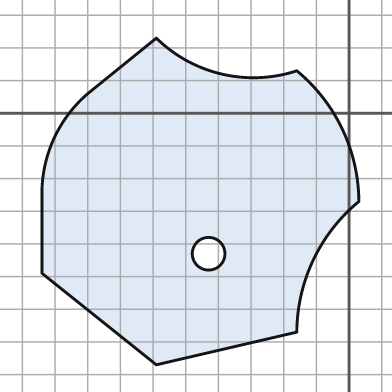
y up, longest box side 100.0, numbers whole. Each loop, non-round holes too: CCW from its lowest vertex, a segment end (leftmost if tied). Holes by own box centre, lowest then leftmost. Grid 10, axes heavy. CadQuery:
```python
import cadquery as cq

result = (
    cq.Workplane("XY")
    .moveTo(-59.0, -77.0)
    .lineTo(-16.0, -67.0)
    .threePointArc((-11.0, -45.0), (3.0, -27.0))
    .threePointArc((-2.0, -5.0), (-16.0, 13.0))
    .threePointArc((-39.0, 12.0), (-59.0, 23.0))
    .lineTo(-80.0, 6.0)
    .threePointArc((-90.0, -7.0), (-94.0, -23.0))
    .lineTo(-94.0, -49.0)
    .close()
    .moveTo(-43.0, -43.0)
    .circle(5.0)
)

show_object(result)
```